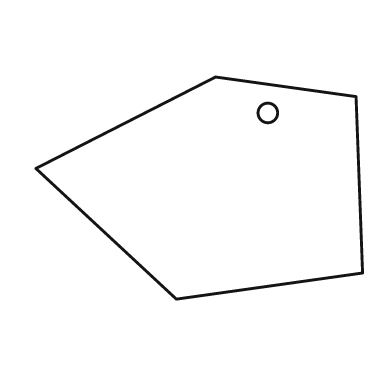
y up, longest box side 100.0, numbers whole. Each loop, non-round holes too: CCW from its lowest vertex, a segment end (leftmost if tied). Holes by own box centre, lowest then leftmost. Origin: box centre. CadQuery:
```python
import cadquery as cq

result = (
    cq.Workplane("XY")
    .moveTo(-7.0, -34.0)
    .lineTo(50.0, -26.0)
    .lineTo(48.0, 28.0)
    .lineTo(5.0, 34.0)
    .lineTo(-50.0, 6.0)
    .close()
    .moveTo(21.0, 23.0)
    .circle(3.0)
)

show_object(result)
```